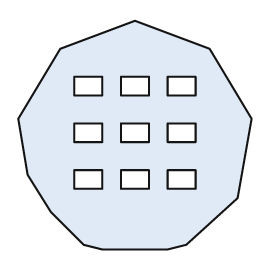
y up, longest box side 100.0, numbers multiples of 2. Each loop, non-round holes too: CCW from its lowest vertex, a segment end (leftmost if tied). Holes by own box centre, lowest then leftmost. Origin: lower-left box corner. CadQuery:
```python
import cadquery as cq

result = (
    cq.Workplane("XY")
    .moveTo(36.0, 0.0)
    .lineTo(64.0, 0.0)
    .lineTo(72.0, 2.0)
    .lineTo(94.0, 22.0)
    .lineTo(100.0, 56.0)
    .lineTo(82.0, 86.0)
    .lineTo(50.0, 98.0)
    .lineTo(18.0, 86.0)
    .lineTo(0.0, 56.0)
    .lineTo(4.0, 32.0)
    .lineTo(14.0, 16.0)
    .lineTo(28.0, 2.0)
    .close()
    .moveTo(24.0, 26.0)
    .lineTo(36.0, 26.0)
    .lineTo(36.0, 34.0)
    .lineTo(24.0, 34.0)
    .close()
    .moveTo(44.0, 26.0)
    .lineTo(56.0, 26.0)
    .lineTo(56.0, 34.0)
    .lineTo(44.0, 34.0)
    .close()
    .moveTo(64.0, 26.0)
    .lineTo(76.0, 26.0)
    .lineTo(76.0, 34.0)
    .lineTo(64.0, 34.0)
    .close()
    .moveTo(24.0, 46.0)
    .lineTo(36.0, 46.0)
    .lineTo(36.0, 54.0)
    .lineTo(24.0, 54.0)
    .close()
    .moveTo(44.0, 46.0)
    .lineTo(56.0, 46.0)
    .lineTo(56.0, 54.0)
    .lineTo(44.0, 54.0)
    .close()
    .moveTo(64.0, 46.0)
    .lineTo(76.0, 46.0)
    .lineTo(76.0, 54.0)
    .lineTo(64.0, 54.0)
    .close()
    .moveTo(24.0, 66.0)
    .lineTo(36.0, 66.0)
    .lineTo(36.0, 74.0)
    .lineTo(24.0, 74.0)
    .close()
    .moveTo(44.0, 66.0)
    .lineTo(56.0, 66.0)
    .lineTo(56.0, 74.0)
    .lineTo(44.0, 74.0)
    .close()
    .moveTo(64.0, 66.0)
    .lineTo(76.0, 66.0)
    .lineTo(76.0, 74.0)
    .lineTo(64.0, 74.0)
    .close()
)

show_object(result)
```